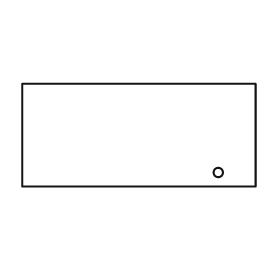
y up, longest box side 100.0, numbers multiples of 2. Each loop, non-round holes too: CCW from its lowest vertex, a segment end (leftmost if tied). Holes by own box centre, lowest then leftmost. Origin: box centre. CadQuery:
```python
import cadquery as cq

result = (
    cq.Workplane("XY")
    .moveTo(-50.0, -22.0)
    .lineTo(50.0, -22.0)
    .lineTo(50.0, 22.0)
    .lineTo(-50.0, 22.0)
    .close()
    .moveTo(34.0, -16.0)
    .circle(2.0)
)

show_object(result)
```